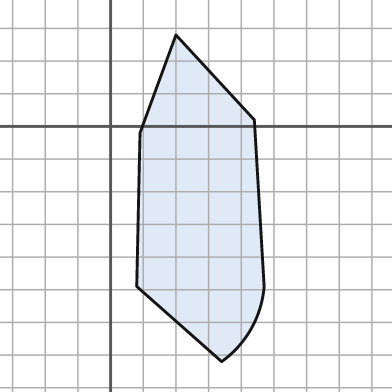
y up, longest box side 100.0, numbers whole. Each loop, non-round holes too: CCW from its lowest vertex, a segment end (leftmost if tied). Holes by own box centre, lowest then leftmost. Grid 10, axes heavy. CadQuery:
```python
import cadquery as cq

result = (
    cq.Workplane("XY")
    .moveTo(34.0, -72.0)
    .threePointArc((43.0, -62.0), (47.0, -49.0))
    .lineTo(44.0, 2.0)
    .lineTo(20.0, 28.0)
    .lineTo(9.0, -2.0)
    .lineTo(8.0, -49.0)
    .close()
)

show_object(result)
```